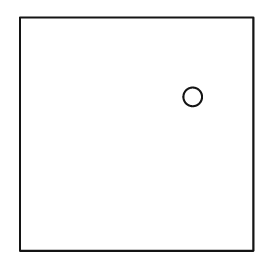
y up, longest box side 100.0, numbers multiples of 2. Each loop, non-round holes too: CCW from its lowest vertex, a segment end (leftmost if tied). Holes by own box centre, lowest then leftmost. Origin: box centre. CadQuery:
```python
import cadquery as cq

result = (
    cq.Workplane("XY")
    .moveTo(-50.0, -50.0)
    .lineTo(50.0, -50.0)
    .lineTo(50.0, 50.0)
    .lineTo(-50.0, 50.0)
    .close()
    .moveTo(24.0, 16.0)
    .circle(4.0)
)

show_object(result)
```